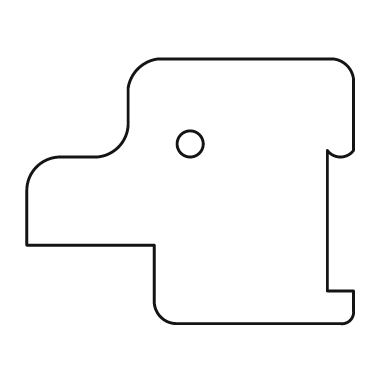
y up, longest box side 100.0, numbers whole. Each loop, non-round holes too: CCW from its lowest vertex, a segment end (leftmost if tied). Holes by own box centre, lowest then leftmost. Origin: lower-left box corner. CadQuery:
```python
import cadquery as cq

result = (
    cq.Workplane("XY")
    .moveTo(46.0, 0.0)
    .lineTo(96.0, 0.0)
    .threePointArc((99.0, 1.0), (100.0, 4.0))
    .lineTo(100.0, 10.0)
    .lineTo(92.0, 10.0)
    .lineTo(92.0, 53.0)
    .threePointArc((96.0, 51.0), (100.0, 53.0))
    .lineTo(100.0, 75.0)
    .threePointArc((98.0, 79.0), (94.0, 81.0))
    .lineTo(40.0, 81.0)
    .threePointArc((34.0, 78.0), (31.0, 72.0))
    .lineTo(31.0, 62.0)
    .threePointArc((28.0, 54.0), (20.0, 51.0))
    .lineTo(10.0, 51.0)
    .threePointArc((3.0, 48.0), (0.0, 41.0))
    .lineTo(0.0, 24.0)
    .lineTo(39.0, 24.0)
    .lineTo(39.0, 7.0)
    .threePointArc((41.0, 2.0), (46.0, 0.0))
    .close()
    .moveTo(50.0, 55.0)
    .circle(4.0)
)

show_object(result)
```